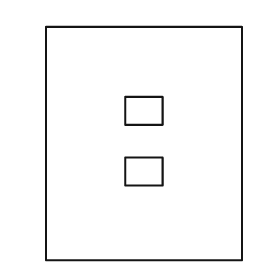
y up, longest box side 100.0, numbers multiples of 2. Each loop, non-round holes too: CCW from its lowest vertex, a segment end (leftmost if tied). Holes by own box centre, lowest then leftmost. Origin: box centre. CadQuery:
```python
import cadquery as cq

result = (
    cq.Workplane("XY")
    .moveTo(-42.0, -50.0)
    .lineTo(42.0, -50.0)
    .lineTo(42.0, 50.0)
    .lineTo(-42.0, 50.0)
    .close()
    .moveTo(-8.0, -18.0)
    .lineTo(8.0, -18.0)
    .lineTo(8.0, -6.0)
    .lineTo(-8.0, -6.0)
    .close()
    .moveTo(-8.0, 8.0)
    .lineTo(8.0, 8.0)
    .lineTo(8.0, 20.0)
    .lineTo(-8.0, 20.0)
    .close()
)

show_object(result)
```